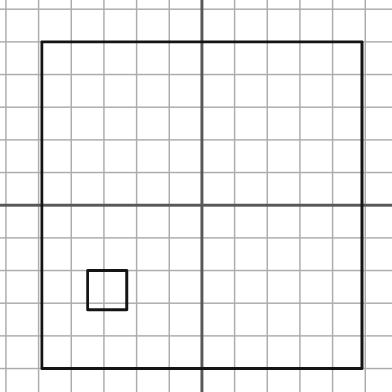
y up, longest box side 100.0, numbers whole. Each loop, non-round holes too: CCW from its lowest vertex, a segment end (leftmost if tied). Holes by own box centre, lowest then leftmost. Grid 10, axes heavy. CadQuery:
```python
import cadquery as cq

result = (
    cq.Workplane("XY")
    .moveTo(-49.0, -50.0)
    .lineTo(49.0, -50.0)
    .lineTo(49.0, 50.0)
    .lineTo(-49.0, 50.0)
    .close()
    .moveTo(-35.0, -32.0)
    .lineTo(-23.0, -32.0)
    .lineTo(-23.0, -20.0)
    .lineTo(-35.0, -20.0)
    .close()
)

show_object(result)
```